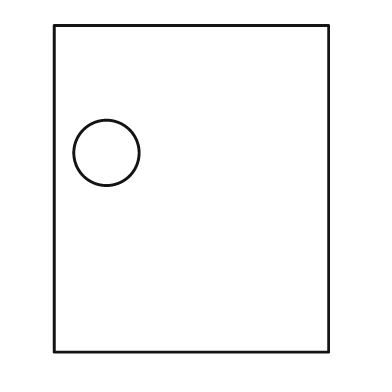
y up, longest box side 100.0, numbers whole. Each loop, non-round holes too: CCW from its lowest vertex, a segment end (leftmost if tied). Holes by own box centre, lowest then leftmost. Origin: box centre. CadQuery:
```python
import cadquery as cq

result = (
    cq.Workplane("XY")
    .moveTo(-42.0, -50.0)
    .lineTo(42.0, -50.0)
    .lineTo(42.0, 50.0)
    .lineTo(-42.0, 50.0)
    .close()
    .moveTo(-26.0, 11.0)
    .circle(10.0)
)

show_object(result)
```